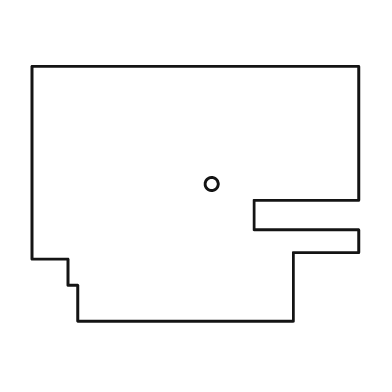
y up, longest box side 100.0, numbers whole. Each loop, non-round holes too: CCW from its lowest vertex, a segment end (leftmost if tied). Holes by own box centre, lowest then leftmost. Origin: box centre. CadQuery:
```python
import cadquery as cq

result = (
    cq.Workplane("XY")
    .moveTo(-36.0, -39.0)
    .lineTo(30.0, -39.0)
    .lineTo(30.0, -18.0)
    .lineTo(50.0, -18.0)
    .lineTo(50.0, -11.0)
    .lineTo(18.0, -11.0)
    .lineTo(18.0, -2.0)
    .lineTo(50.0, -2.0)
    .lineTo(50.0, 39.0)
    .lineTo(-50.0, 39.0)
    .lineTo(-50.0, -20.0)
    .lineTo(-39.0, -20.0)
    .lineTo(-39.0, -28.0)
    .lineTo(-36.0, -28.0)
    .close()
    .moveTo(5.0, 3.0)
    .circle(2.0)
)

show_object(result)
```